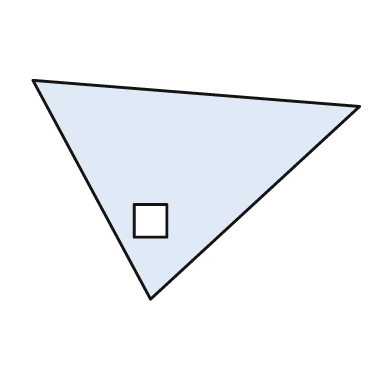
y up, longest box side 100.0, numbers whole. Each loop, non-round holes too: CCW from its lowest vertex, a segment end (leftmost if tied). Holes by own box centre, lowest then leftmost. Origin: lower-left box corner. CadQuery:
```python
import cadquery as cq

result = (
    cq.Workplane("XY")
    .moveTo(36.0, 0.0)
    .lineTo(100.0, 59.0)
    .lineTo(0.0, 67.0)
    .close()
    .moveTo(31.0, 19.0)
    .lineTo(41.0, 19.0)
    .lineTo(41.0, 29.0)
    .lineTo(31.0, 29.0)
    .close()
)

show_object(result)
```